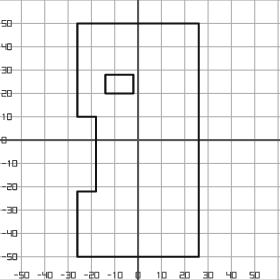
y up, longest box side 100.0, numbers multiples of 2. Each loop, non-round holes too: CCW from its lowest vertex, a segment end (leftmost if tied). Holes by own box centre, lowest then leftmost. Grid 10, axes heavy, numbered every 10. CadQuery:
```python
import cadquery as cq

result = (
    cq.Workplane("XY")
    .moveTo(-26.0, -50.0)
    .lineTo(26.0, -50.0)
    .lineTo(26.0, 50.0)
    .lineTo(-26.0, 50.0)
    .lineTo(-26.0, 10.0)
    .lineTo(-18.0, 10.0)
    .lineTo(-18.0, -22.0)
    .lineTo(-26.0, -22.0)
    .close()
    .moveTo(-14.0, 20.0)
    .lineTo(-2.0, 20.0)
    .lineTo(-2.0, 28.0)
    .lineTo(-14.0, 28.0)
    .close()
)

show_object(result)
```